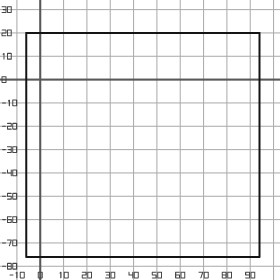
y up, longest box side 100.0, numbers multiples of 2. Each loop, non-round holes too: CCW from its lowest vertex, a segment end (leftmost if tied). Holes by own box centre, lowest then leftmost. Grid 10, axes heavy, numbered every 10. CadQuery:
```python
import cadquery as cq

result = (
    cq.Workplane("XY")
    .moveTo(-6.0, -76.0)
    .lineTo(94.0, -76.0)
    .lineTo(94.0, 20.0)
    .lineTo(-6.0, 20.0)
    .close()
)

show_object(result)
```